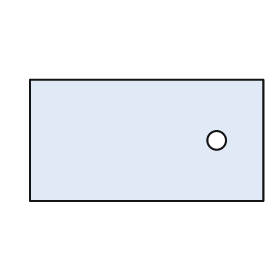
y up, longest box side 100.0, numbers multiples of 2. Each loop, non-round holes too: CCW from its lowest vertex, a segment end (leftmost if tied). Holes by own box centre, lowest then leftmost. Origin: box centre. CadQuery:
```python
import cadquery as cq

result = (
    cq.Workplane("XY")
    .moveTo(-50.0, -26.0)
    .lineTo(50.0, -26.0)
    .lineTo(50.0, 26.0)
    .lineTo(-50.0, 26.0)
    .close()
    .moveTo(30.0, 0.0)
    .circle(4.0)
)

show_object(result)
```